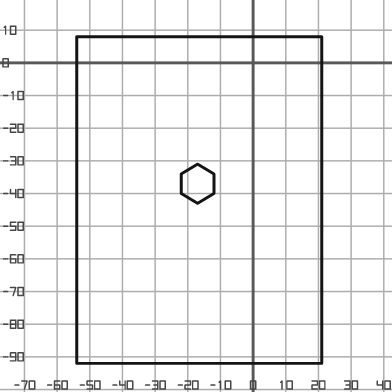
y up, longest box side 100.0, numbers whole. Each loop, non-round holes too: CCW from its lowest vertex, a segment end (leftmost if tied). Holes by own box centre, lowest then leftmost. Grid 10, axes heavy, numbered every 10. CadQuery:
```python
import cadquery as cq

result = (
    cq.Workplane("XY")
    .moveTo(-54.0, -92.0)
    .lineTo(21.0, -92.0)
    .lineTo(21.0, 8.0)
    .lineTo(-54.0, 8.0)
    .close()
    .moveTo(-17.0, -43.0)
    .lineTo(-12.0, -40.0)
    .lineTo(-12.0, -34.0)
    .lineTo(-17.0, -31.0)
    .lineTo(-22.0, -34.0)
    .lineTo(-22.0, -40.0)
    .close()
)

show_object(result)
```